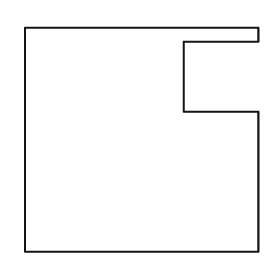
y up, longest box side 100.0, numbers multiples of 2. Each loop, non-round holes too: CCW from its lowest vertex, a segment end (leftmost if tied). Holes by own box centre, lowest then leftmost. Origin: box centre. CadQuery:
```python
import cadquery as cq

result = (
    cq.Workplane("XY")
    .moveTo(-50.0, -48.0)
    .lineTo(50.0, -48.0)
    .lineTo(50.0, 12.0)
    .lineTo(18.0, 12.0)
    .lineTo(18.0, 42.0)
    .lineTo(50.0, 42.0)
    .lineTo(50.0, 48.0)
    .lineTo(-50.0, 48.0)
    .close()
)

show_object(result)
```